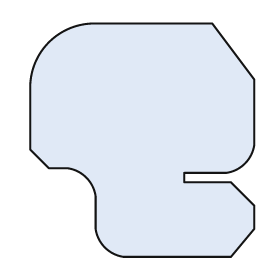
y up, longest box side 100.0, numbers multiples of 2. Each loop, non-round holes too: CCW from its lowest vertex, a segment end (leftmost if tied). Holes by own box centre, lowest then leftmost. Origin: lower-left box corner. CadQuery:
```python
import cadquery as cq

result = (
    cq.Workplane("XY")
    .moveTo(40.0, 0.0)
    .lineTo(86.0, 0.0)
    .lineTo(96.0, 12.0)
    .lineTo(96.0, 22.0)
    .lineTo(86.0, 32.0)
    .lineTo(66.0, 32.0)
    .lineTo(66.0, 36.0)
    .lineTo(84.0, 36.0)
    .threePointArc((92.0, 40.0), (96.0, 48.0))
    .lineTo(96.0, 76.0)
    .lineTo(78.0, 100.0)
    .lineTo(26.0, 100.0)
    .threePointArc((8.0, 92.0), (0.0, 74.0))
    .lineTo(0.0, 46.0)
    .lineTo(8.0, 38.0)
    .lineTo(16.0, 38.0)
    .threePointArc((24.0, 34.0), (28.0, 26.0))
    .lineTo(28.0, 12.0)
    .threePointArc((32.0, 4.0), (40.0, 0.0))
    .close()
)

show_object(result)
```